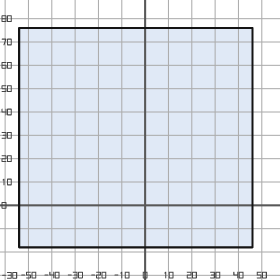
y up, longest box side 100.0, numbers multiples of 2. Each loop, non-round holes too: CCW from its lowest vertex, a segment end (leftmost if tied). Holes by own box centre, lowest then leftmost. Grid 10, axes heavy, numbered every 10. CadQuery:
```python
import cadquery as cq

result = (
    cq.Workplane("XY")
    .moveTo(-54.0, -18.0)
    .lineTo(46.0, -18.0)
    .lineTo(46.0, 76.0)
    .lineTo(-54.0, 76.0)
    .close()
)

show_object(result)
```